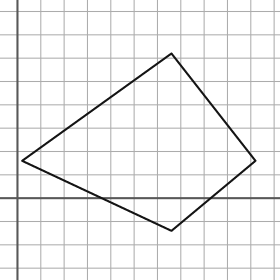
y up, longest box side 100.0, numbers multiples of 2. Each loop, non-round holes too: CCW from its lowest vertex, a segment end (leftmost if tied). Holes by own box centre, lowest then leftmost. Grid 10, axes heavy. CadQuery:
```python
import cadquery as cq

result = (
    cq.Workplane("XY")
    .moveTo(66.0, -14.0)
    .lineTo(102.0, 16.0)
    .lineTo(66.0, 62.0)
    .lineTo(2.0, 16.0)
    .close()
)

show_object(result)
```